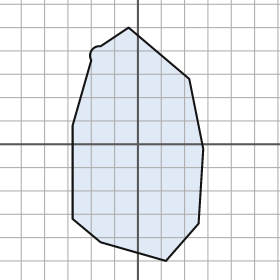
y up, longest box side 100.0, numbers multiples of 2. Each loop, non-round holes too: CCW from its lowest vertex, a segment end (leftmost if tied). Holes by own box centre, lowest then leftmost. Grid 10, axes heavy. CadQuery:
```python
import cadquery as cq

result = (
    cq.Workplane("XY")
    .moveTo(12.0, -50.0)
    .lineTo(26.0, -34.0)
    .lineTo(28.0, -2.0)
    .lineTo(22.0, 28.0)
    .lineTo(-4.0, 50.0)
    .lineTo(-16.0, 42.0)
    .threePointArc((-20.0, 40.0), (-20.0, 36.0))
    .lineTo(-28.0, 8.0)
    .lineTo(-28.0, -32.0)
    .lineTo(-16.0, -42.0)
    .close()
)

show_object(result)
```